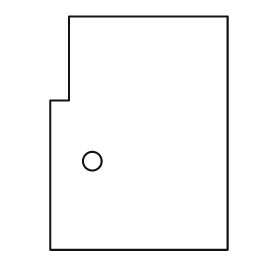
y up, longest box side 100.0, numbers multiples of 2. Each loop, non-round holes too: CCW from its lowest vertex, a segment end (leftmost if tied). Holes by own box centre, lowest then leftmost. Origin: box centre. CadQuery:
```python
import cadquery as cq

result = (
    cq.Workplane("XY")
    .moveTo(-38.0, -50.0)
    .lineTo(38.0, -50.0)
    .lineTo(38.0, 50.0)
    .lineTo(-30.0, 50.0)
    .lineTo(-30.0, 14.0)
    .lineTo(-38.0, 14.0)
    .close()
    .moveTo(-20.0, -12.0)
    .circle(4.0)
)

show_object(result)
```